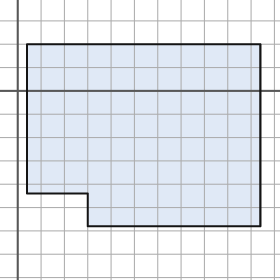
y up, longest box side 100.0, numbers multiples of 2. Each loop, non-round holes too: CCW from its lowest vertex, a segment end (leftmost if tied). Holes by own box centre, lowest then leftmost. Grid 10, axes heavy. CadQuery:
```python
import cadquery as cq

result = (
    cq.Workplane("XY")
    .moveTo(30.0, -58.0)
    .lineTo(104.0, -58.0)
    .lineTo(104.0, 20.0)
    .lineTo(4.0, 20.0)
    .lineTo(4.0, -44.0)
    .lineTo(30.0, -44.0)
    .close()
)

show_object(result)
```